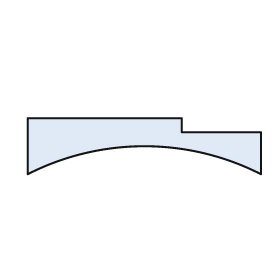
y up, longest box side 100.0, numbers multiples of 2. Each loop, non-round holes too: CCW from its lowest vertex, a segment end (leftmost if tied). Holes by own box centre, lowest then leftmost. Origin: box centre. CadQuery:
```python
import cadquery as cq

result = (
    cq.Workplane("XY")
    .moveTo(-50.0, -12.0)
    .threePointArc((0.0, 0.0), (50.0, -12.0))
    .lineTo(50.0, 6.0)
    .lineTo(16.0, 6.0)
    .lineTo(16.0, 12.0)
    .lineTo(-50.0, 12.0)
    .close()
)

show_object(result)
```